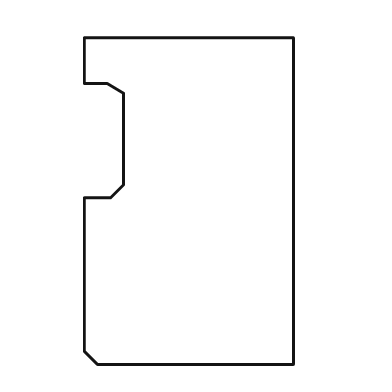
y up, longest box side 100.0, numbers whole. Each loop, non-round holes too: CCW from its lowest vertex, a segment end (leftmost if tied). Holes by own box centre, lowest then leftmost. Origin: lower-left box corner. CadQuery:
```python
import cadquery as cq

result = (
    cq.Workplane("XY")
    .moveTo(4.0, 0.0)
    .lineTo(64.0, 0.0)
    .lineTo(64.0, 100.0)
    .lineTo(0.0, 100.0)
    .lineTo(0.0, 86.0)
    .lineTo(7.0, 86.0)
    .lineTo(12.0, 83.0)
    .lineTo(12.0, 55.0)
    .lineTo(8.0, 51.0)
    .lineTo(0.0, 51.0)
    .lineTo(0.0, 4.0)
    .close()
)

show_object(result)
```